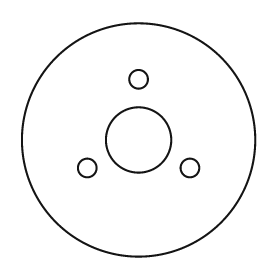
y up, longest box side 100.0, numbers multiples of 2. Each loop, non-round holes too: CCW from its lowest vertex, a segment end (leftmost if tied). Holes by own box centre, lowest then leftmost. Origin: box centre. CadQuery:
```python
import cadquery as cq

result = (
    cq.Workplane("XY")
    .moveTo(0.0, 0.0)
    .circle(50.0)
    .moveTo(-22.0, -12.0)
    .circle(4.0)
    .moveTo(22.0, -12.0)
    .circle(4.0)
    .moveTo(0.0, 0.0)
    .circle(14.0)
    .moveTo(0.0, 26.0)
    .circle(4.0)
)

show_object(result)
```